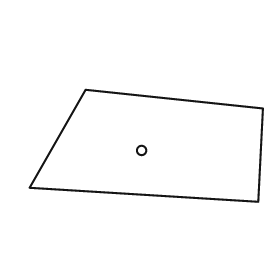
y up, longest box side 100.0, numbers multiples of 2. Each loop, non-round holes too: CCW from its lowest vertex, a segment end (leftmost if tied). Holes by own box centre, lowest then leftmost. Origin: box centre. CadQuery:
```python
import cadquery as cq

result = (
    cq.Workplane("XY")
    .moveTo(48.0, -24.0)
    .lineTo(50.0, 16.0)
    .lineTo(-26.0, 24.0)
    .lineTo(-50.0, -18.0)
    .close()
    .moveTo(-2.0, -2.0)
    .circle(2.0)
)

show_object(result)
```